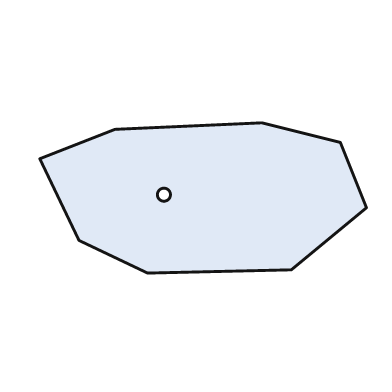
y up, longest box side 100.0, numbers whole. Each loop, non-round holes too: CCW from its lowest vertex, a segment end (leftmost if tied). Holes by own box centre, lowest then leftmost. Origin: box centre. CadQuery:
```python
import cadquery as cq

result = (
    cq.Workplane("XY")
    .moveTo(-17.0, -23.0)
    .lineTo(27.0, -22.0)
    .lineTo(50.0, -3.0)
    .lineTo(42.0, 17.0)
    .lineTo(18.0, 23.0)
    .lineTo(-27.0, 21.0)
    .lineTo(-50.0, 12.0)
    .lineTo(-38.0, -13.0)
    .close()
    .moveTo(-12.0, 1.0)
    .circle(2.0)
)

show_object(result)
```